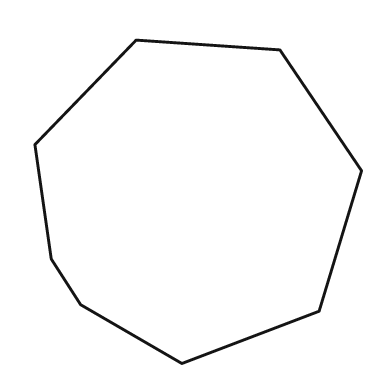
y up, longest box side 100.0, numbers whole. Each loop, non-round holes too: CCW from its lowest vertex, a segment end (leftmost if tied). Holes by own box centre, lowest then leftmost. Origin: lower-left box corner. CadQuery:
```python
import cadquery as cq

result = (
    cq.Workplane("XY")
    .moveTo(45.0, 0.0)
    .lineTo(87.0, 16.0)
    .lineTo(100.0, 59.0)
    .lineTo(75.0, 96.0)
    .lineTo(31.0, 99.0)
    .lineTo(0.0, 67.0)
    .lineTo(5.0, 32.0)
    .lineTo(14.0, 18.0)
    .close()
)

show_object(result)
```